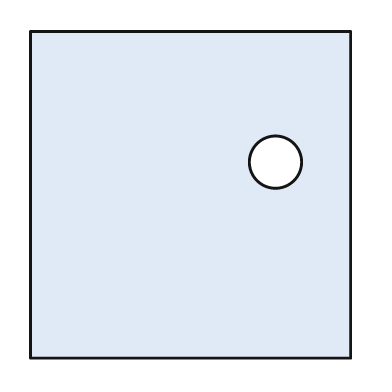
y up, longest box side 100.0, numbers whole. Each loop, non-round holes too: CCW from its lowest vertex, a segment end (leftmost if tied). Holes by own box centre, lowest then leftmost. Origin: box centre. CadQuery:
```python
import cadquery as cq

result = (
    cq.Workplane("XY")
    .moveTo(-49.0, -50.0)
    .lineTo(49.0, -50.0)
    .lineTo(49.0, 50.0)
    .lineTo(-49.0, 50.0)
    .close()
    .moveTo(26.0, 10.0)
    .circle(8.0)
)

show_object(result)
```